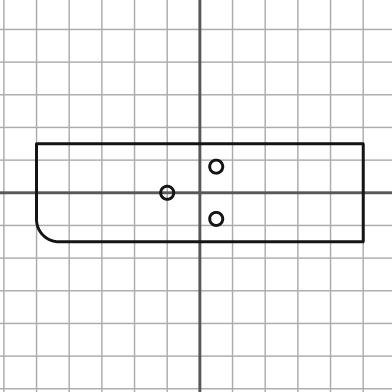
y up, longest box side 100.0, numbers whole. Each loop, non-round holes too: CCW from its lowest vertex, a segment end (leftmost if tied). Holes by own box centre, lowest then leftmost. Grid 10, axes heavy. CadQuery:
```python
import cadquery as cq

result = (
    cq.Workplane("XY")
    .moveTo(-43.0, -15.0)
    .lineTo(50.0, -15.0)
    .lineTo(50.0, 15.0)
    .lineTo(-50.0, 15.0)
    .lineTo(-50.0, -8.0)
    .threePointArc((-48.0, -13.0), (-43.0, -15.0))
    .close()
    .moveTo(5.0, -8.0)
    .circle(2.0)
    .moveTo(-10.0, 0.0)
    .circle(2.0)
    .moveTo(5.0, 8.0)
    .circle(2.0)
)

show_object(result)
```